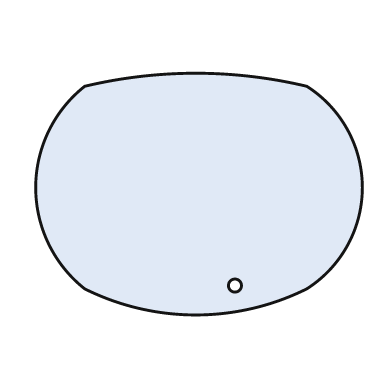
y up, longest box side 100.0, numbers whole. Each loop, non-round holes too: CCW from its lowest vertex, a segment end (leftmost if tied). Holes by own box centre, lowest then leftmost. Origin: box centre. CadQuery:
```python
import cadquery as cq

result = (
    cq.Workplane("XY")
    .moveTo(-35.0, -29.0)
    .threePointArc((-1.0, -37.0), (33.0, -29.0))
    .threePointArc((50.0, 2.0), (33.0, 33.0))
    .threePointArc((-1.0, 37.0), (-35.0, 33.0))
    .threePointArc((-50.0, 2.0), (-35.0, -29.0))
    .close()
    .moveTo(11.0, -28.0)
    .circle(2.0)
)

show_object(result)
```